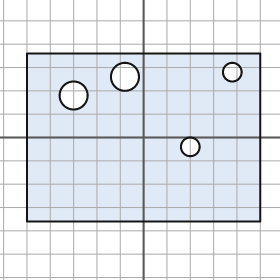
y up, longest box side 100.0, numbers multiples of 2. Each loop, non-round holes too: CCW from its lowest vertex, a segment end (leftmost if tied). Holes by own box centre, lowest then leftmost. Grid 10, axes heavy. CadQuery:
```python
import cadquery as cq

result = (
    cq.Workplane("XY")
    .moveTo(-50.0, -36.0)
    .lineTo(50.0, -36.0)
    .lineTo(50.0, 36.0)
    .lineTo(-50.0, 36.0)
    .close()
    .moveTo(20.0, -4.0)
    .circle(4.0)
    .moveTo(-30.0, 18.0)
    .circle(6.0)
    .moveTo(-8.0, 26.0)
    .circle(6.0)
    .moveTo(38.0, 28.0)
    .circle(4.0)
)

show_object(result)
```